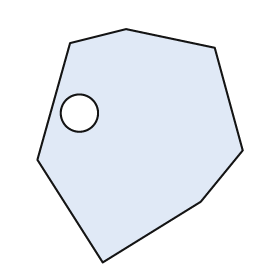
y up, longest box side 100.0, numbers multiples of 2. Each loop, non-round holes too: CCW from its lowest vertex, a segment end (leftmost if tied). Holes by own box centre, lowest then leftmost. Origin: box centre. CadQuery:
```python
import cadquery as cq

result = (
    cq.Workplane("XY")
    .moveTo(-16.0, -50.0)
    .lineTo(26.0, -24.0)
    .lineTo(44.0, -2.0)
    .lineTo(32.0, 42.0)
    .lineTo(-6.0, 50.0)
    .lineTo(-30.0, 44.0)
    .lineTo(-44.0, -6.0)
    .close()
    .moveTo(-26.0, 14.0)
    .circle(8.0)
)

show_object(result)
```